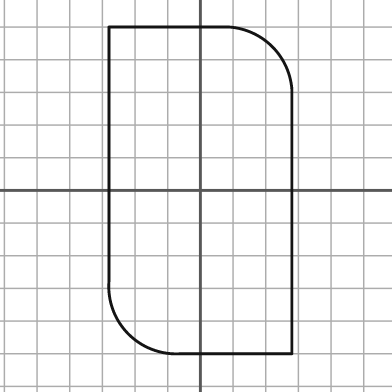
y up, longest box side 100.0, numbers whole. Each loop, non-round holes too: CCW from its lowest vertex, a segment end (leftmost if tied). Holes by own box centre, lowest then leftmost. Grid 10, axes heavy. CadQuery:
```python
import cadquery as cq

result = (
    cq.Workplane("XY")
    .moveTo(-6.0, -50.0)
    .lineTo(28.0, -50.0)
    .lineTo(28.0, 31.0)
    .threePointArc((22.0, 44.0), (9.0, 50.0))
    .lineTo(-28.0, 50.0)
    .lineTo(-28.0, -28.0)
    .threePointArc((-22.0, -44.0), (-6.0, -50.0))
    .close()
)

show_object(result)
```